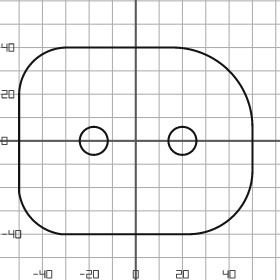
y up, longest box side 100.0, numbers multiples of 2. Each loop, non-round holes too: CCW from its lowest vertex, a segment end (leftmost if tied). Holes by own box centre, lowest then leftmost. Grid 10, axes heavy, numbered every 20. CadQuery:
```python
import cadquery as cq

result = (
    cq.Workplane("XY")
    .moveTo(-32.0, -40.0)
    .lineTo(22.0, -40.0)
    .threePointArc((42.0, -32.0), (50.0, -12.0))
    .lineTo(50.0, 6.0)
    .threePointArc((40.0, 30.0), (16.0, 40.0))
    .lineTo(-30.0, 40.0)
    .threePointArc((-44.0, 34.0), (-50.0, 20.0))
    .lineTo(-50.0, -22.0)
    .threePointArc((-44.0, -34.0), (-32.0, -40.0))
    .close()
    .moveTo(-18.0, 0.0)
    .circle(6.0)
    .moveTo(20.0, 0.0)
    .circle(6.0)
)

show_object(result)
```